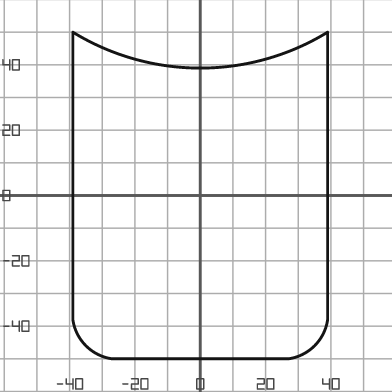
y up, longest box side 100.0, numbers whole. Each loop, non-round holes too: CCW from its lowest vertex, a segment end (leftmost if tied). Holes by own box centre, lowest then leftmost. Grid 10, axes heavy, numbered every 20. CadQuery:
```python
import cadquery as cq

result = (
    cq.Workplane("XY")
    .moveTo(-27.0, -50.0)
    .lineTo(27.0, -50.0)
    .threePointArc((35.0, -46.0), (39.0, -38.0))
    .lineTo(39.0, 50.0)
    .threePointArc((0.0, 39.0), (-39.0, 50.0))
    .lineTo(-39.0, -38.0)
    .threePointArc((-35.0, -46.0), (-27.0, -50.0))
    .close()
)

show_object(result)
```